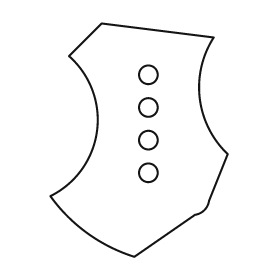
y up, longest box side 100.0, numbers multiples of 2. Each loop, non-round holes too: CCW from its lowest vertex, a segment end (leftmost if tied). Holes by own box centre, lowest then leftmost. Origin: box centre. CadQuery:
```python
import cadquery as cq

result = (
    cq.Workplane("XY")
    .moveTo(-2.0, -50.0)
    .lineTo(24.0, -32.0)
    .threePointArc((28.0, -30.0), (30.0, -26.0))
    .lineTo(38.0, -6.0)
    .threePointArc((26.0, 18.0), (32.0, 44.0))
    .lineTo(-16.0, 50.0)
    .lineTo(-30.0, 36.0)
    .threePointArc((-18.0, 4.0), (-38.0, -24.0))
    .threePointArc((-22.0, -40.0), (-2.0, -50.0))
    .close()
    .moveTo(4.0, -14.0)
    .circle(4.0)
    .moveTo(4.0, 0.0)
    .circle(4.0)
    .moveTo(4.0, 14.0)
    .circle(4.0)
    .moveTo(4.0, 28.0)
    .circle(4.0)
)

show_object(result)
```